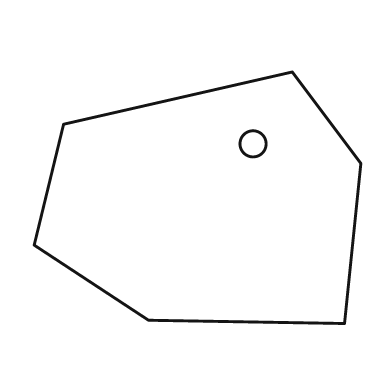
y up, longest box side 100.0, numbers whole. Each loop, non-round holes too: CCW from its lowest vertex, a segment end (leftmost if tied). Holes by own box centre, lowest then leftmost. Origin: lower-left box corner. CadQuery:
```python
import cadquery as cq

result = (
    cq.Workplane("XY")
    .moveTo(95.0, 0.0)
    .lineTo(100.0, 49.0)
    .lineTo(79.0, 77.0)
    .lineTo(9.0, 61.0)
    .lineTo(0.0, 24.0)
    .lineTo(35.0, 1.0)
    .close()
    .moveTo(67.0, 55.0)
    .circle(4.0)
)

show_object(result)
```